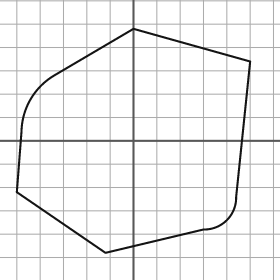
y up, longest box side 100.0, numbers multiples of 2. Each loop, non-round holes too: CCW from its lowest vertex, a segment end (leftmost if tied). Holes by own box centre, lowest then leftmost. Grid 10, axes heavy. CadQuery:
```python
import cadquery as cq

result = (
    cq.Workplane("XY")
    .moveTo(-12.0, -48.0)
    .lineTo(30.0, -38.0)
    .threePointArc((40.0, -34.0), (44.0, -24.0))
    .lineTo(50.0, 34.0)
    .lineTo(0.0, 48.0)
    .lineTo(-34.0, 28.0)
    .threePointArc((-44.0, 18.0), (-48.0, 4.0))
    .lineTo(-50.0, -22.0)
    .close()
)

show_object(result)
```